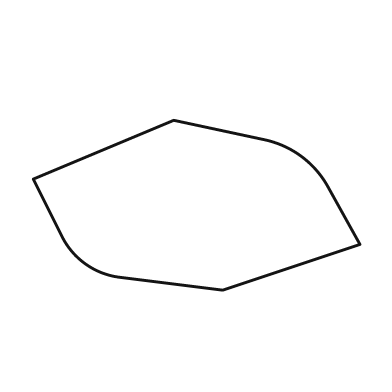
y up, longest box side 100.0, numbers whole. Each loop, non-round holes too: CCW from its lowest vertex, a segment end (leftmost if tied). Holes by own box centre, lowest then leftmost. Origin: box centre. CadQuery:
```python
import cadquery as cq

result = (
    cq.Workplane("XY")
    .moveTo(8.0, -26.0)
    .lineTo(50.0, -12.0)
    .lineTo(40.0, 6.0)
    .threePointArc((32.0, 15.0), (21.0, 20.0))
    .lineTo(-7.0, 26.0)
    .lineTo(-50.0, 8.0)
    .lineTo(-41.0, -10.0)
    .threePointArc((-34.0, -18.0), (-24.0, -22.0))
    .close()
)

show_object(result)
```